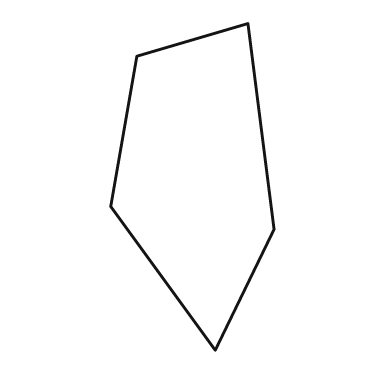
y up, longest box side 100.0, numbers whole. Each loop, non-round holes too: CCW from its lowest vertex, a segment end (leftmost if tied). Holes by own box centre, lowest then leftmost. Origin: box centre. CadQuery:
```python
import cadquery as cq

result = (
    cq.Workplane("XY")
    .moveTo(7.0, -50.0)
    .lineTo(25.0, -13.0)
    .lineTo(17.0, 50.0)
    .lineTo(-17.0, 40.0)
    .lineTo(-25.0, -6.0)
    .close()
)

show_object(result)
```